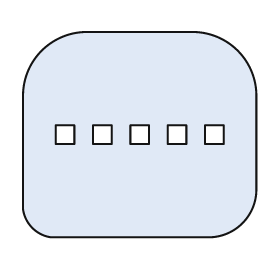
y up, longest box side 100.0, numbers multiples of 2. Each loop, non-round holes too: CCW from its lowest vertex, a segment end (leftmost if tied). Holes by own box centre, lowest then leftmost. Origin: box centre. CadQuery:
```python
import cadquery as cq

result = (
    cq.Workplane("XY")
    .moveTo(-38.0, -44.0)
    .lineTo(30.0, -44.0)
    .threePointArc((44.0, -38.0), (50.0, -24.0))
    .lineTo(50.0, 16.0)
    .threePointArc((42.0, 36.0), (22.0, 44.0))
    .lineTo(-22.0, 44.0)
    .threePointArc((-42.0, 36.0), (-50.0, 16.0))
    .lineTo(-50.0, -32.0)
    .threePointArc((-46.0, -40.0), (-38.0, -44.0))
    .close()
    .moveTo(-36.0, -4.0)
    .lineTo(-28.0, -4.0)
    .lineTo(-28.0, 4.0)
    .lineTo(-36.0, 4.0)
    .close()
    .moveTo(-20.0, -4.0)
    .lineTo(-12.0, -4.0)
    .lineTo(-12.0, 4.0)
    .lineTo(-20.0, 4.0)
    .close()
    .moveTo(-4.0, -4.0)
    .lineTo(4.0, -4.0)
    .lineTo(4.0, 4.0)
    .lineTo(-4.0, 4.0)
    .close()
    .moveTo(12.0, -4.0)
    .lineTo(20.0, -4.0)
    .lineTo(20.0, 4.0)
    .lineTo(12.0, 4.0)
    .close()
    .moveTo(28.0, -4.0)
    .lineTo(36.0, -4.0)
    .lineTo(36.0, 4.0)
    .lineTo(28.0, 4.0)
    .close()
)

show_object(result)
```